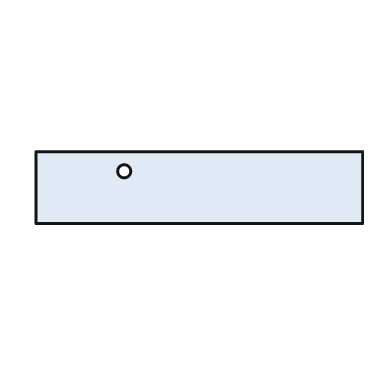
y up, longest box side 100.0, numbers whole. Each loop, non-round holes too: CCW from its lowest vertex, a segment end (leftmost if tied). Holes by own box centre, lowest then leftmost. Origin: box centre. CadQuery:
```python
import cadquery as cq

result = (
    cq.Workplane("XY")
    .moveTo(-50.0, -11.0)
    .lineTo(50.0, -11.0)
    .lineTo(50.0, 11.0)
    .lineTo(-50.0, 11.0)
    .close()
    .moveTo(-23.0, 5.0)
    .circle(2.0)
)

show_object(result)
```